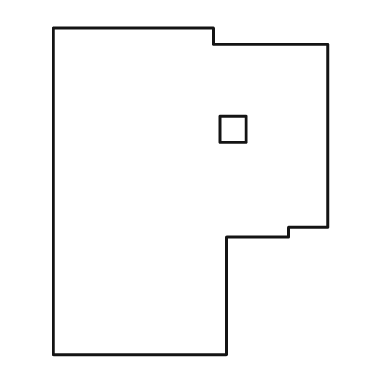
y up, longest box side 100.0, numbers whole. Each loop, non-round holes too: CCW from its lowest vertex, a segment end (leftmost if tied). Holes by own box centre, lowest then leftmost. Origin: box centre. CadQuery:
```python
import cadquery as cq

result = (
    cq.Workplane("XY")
    .moveTo(-42.0, -50.0)
    .lineTo(11.0, -50.0)
    .lineTo(11.0, -14.0)
    .lineTo(30.0, -14.0)
    .lineTo(30.0, -11.0)
    .lineTo(42.0, -11.0)
    .lineTo(42.0, 45.0)
    .lineTo(7.0, 45.0)
    .lineTo(7.0, 50.0)
    .lineTo(-42.0, 50.0)
    .close()
    .moveTo(9.0, 15.0)
    .lineTo(17.0, 15.0)
    .lineTo(17.0, 23.0)
    .lineTo(9.0, 23.0)
    .close()
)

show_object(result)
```